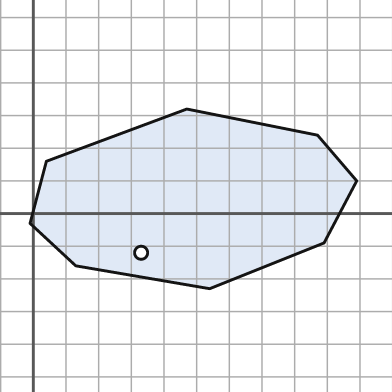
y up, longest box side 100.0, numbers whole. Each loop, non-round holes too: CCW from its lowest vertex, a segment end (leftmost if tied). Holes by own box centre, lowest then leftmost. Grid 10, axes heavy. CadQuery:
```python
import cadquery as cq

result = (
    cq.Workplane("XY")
    .moveTo(54.0, -23.0)
    .lineTo(89.0, -9.0)
    .lineTo(99.0, 10.0)
    .lineTo(87.0, 24.0)
    .lineTo(47.0, 32.0)
    .lineTo(4.0, 16.0)
    .lineTo(-1.0, -3.0)
    .lineTo(13.0, -16.0)
    .close()
    .moveTo(33.0, -12.0)
    .circle(2.0)
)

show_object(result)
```